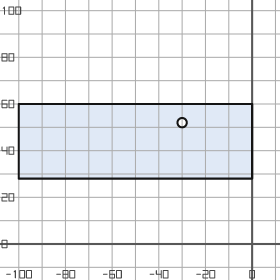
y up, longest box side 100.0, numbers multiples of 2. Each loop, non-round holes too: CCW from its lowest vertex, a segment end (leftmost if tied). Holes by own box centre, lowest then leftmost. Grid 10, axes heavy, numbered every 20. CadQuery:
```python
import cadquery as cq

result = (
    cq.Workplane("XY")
    .moveTo(-100.0, 28.0)
    .lineTo(0.0, 28.0)
    .lineTo(0.0, 60.0)
    .lineTo(-100.0, 60.0)
    .close()
    .moveTo(-30.0, 52.0)
    .circle(2.0)
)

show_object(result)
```